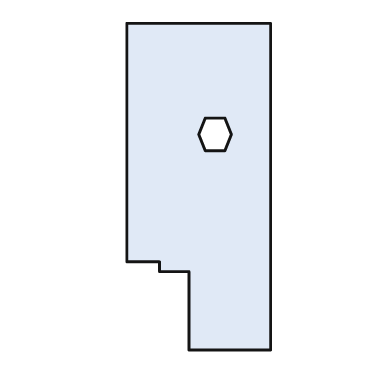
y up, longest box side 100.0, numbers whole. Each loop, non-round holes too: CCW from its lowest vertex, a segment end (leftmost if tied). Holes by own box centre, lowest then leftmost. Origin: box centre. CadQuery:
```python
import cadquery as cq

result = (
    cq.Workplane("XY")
    .moveTo(-3.0, -50.0)
    .lineTo(22.0, -50.0)
    .lineTo(22.0, 50.0)
    .lineTo(-22.0, 50.0)
    .lineTo(-22.0, -23.0)
    .lineTo(-12.0, -23.0)
    .lineTo(-12.0, -26.0)
    .lineTo(-3.0, -26.0)
    .close()
    .moveTo(2.0, 11.0)
    .lineTo(8.0, 11.0)
    .lineTo(10.0, 16.0)
    .lineTo(8.0, 21.0)
    .lineTo(2.0, 21.0)
    .lineTo(0.0, 16.0)
    .close()
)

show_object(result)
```